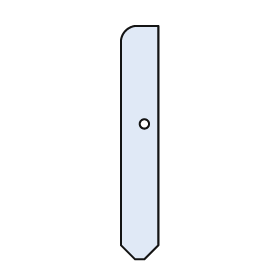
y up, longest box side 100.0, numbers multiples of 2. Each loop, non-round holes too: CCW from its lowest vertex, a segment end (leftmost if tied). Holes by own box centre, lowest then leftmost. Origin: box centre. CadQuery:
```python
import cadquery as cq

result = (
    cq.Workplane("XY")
    .moveTo(-2.0, -50.0)
    .lineTo(2.0, -50.0)
    .lineTo(8.0, -44.0)
    .lineTo(8.0, 50.0)
    .lineTo(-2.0, 50.0)
    .threePointArc((-6.0, 48.0), (-8.0, 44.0))
    .lineTo(-8.0, -44.0)
    .close()
    .moveTo(2.0, 8.0)
    .circle(2.0)
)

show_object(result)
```